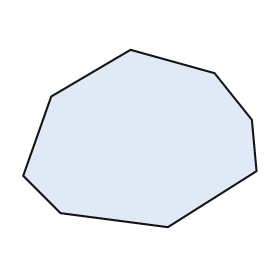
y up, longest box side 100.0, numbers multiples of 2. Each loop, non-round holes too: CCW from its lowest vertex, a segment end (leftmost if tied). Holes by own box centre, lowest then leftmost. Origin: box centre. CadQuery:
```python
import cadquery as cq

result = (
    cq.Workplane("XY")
    .moveTo(12.0, -38.0)
    .lineTo(50.0, -14.0)
    .lineTo(48.0, 8.0)
    .lineTo(32.0, 28.0)
    .lineTo(-4.0, 38.0)
    .lineTo(-38.0, 18.0)
    .lineTo(-50.0, -16.0)
    .lineTo(-34.0, -32.0)
    .close()
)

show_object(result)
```